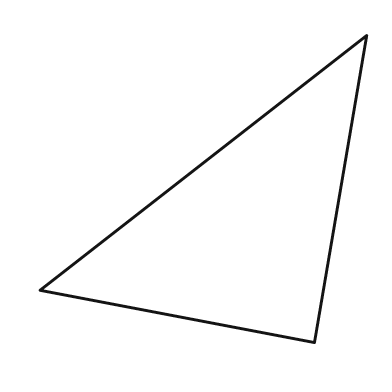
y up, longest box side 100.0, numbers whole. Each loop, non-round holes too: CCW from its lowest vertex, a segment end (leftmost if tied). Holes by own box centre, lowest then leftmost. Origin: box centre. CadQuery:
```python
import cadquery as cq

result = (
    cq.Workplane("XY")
    .moveTo(34.0, -47.0)
    .lineTo(50.0, 47.0)
    .lineTo(-50.0, -31.0)
    .close()
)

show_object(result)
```